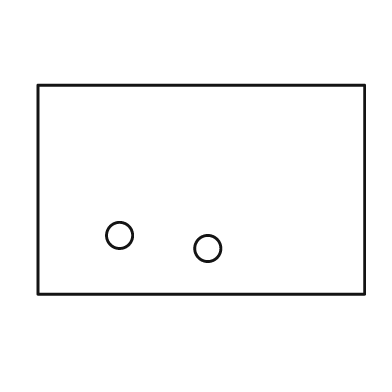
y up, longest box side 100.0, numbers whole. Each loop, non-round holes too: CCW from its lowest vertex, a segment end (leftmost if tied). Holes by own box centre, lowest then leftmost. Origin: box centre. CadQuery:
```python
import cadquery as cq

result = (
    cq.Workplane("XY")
    .moveTo(-50.0, -32.0)
    .lineTo(50.0, -32.0)
    .lineTo(50.0, 32.0)
    .lineTo(-50.0, 32.0)
    .close()
    .moveTo(2.0, -18.0)
    .circle(4.0)
    .moveTo(-25.0, -14.0)
    .circle(4.0)
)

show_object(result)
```